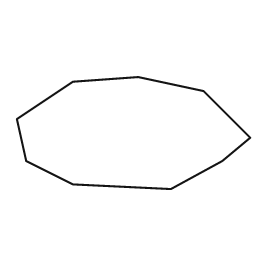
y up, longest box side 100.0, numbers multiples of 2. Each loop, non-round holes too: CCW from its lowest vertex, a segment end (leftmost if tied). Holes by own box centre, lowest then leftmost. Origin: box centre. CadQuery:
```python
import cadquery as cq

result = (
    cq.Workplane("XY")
    .moveTo(16.0, -24.0)
    .lineTo(38.0, -12.0)
    .lineTo(50.0, -2.0)
    .lineTo(30.0, 18.0)
    .lineTo(2.0, 24.0)
    .lineTo(-26.0, 22.0)
    .lineTo(-50.0, 6.0)
    .lineTo(-46.0, -12.0)
    .lineTo(-26.0, -22.0)
    .close()
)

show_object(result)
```